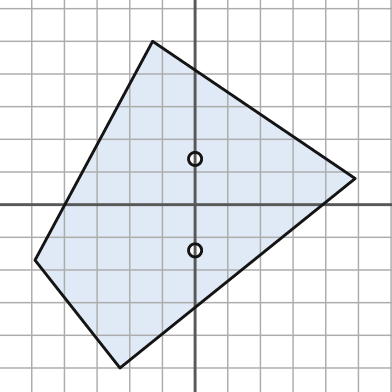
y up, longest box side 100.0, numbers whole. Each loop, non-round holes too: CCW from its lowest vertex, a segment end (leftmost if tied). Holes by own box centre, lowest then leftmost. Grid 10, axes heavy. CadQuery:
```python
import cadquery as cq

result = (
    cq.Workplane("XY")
    .moveTo(-23.0, -50.0)
    .lineTo(49.0, 8.0)
    .lineTo(-13.0, 50.0)
    .lineTo(-49.0, -17.0)
    .close()
    .moveTo(0.0, -14.0)
    .circle(2.0)
    .moveTo(0.0, 14.0)
    .circle(2.0)
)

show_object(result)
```